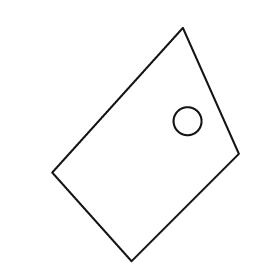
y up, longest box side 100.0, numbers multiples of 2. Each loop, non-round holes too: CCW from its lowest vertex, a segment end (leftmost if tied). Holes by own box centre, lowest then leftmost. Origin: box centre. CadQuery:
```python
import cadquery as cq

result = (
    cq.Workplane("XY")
    .moveTo(-6.0, -50.0)
    .lineTo(40.0, -4.0)
    .lineTo(16.0, 50.0)
    .lineTo(-40.0, -12.0)
    .close()
    .moveTo(18.0, 10.0)
    .circle(6.0)
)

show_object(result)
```